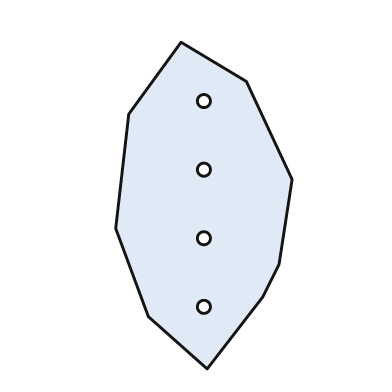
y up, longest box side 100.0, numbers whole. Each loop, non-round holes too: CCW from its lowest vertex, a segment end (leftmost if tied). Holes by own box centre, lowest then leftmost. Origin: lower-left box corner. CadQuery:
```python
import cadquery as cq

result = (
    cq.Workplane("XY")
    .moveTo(28.0, 0.0)
    .lineTo(45.0, 22.0)
    .lineTo(50.0, 32.0)
    .lineTo(54.0, 58.0)
    .lineTo(40.0, 88.0)
    .lineTo(20.0, 100.0)
    .lineTo(4.0, 78.0)
    .lineTo(0.0, 43.0)
    .lineTo(10.0, 16.0)
    .close()
    .moveTo(27.0, 19.0)
    .circle(2.0)
    .moveTo(27.0, 40.0)
    .circle(2.0)
    .moveTo(27.0, 61.0)
    .circle(2.0)
    .moveTo(27.0, 82.0)
    .circle(2.0)
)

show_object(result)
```